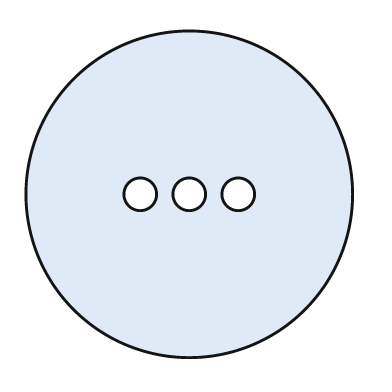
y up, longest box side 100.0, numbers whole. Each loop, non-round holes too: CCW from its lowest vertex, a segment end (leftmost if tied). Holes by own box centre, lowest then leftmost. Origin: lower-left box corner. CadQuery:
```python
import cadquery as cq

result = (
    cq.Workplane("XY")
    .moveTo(50.0, 50.0)
    .circle(50.0)
    .moveTo(35.0, 50.0)
    .circle(5.0)
    .moveTo(50.0, 50.0)
    .circle(5.0)
    .moveTo(65.0, 50.0)
    .circle(5.0)
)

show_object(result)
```